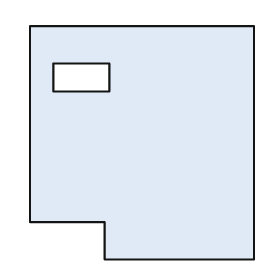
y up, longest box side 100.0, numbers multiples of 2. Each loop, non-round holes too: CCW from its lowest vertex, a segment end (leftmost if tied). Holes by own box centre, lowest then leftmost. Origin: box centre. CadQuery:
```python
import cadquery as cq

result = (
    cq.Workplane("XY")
    .moveTo(-16.0, -50.0)
    .lineTo(48.0, -50.0)
    .lineTo(48.0, 50.0)
    .lineTo(-48.0, 50.0)
    .lineTo(-48.0, -34.0)
    .lineTo(-16.0, -34.0)
    .close()
    .moveTo(-38.0, 22.0)
    .lineTo(-14.0, 22.0)
    .lineTo(-14.0, 34.0)
    .lineTo(-38.0, 34.0)
    .close()
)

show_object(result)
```